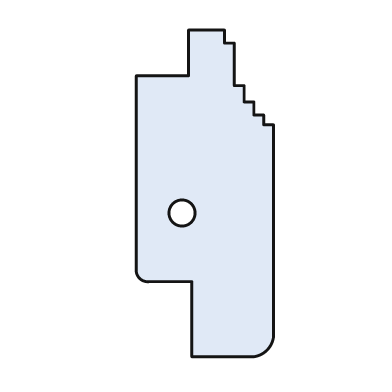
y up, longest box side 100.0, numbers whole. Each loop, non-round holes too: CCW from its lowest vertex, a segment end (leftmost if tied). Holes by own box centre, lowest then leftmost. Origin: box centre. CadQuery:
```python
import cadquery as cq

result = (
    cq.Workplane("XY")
    .moveTo(-4.0, -50.0)
    .lineTo(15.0, -50.0)
    .threePointArc((19.0, -48.0), (21.0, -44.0))
    .lineTo(21.0, 21.0)
    .lineTo(18.0, 21.0)
    .lineTo(18.0, 24.0)
    .lineTo(15.0, 24.0)
    .lineTo(15.0, 28.0)
    .lineTo(12.0, 28.0)
    .lineTo(12.0, 33.0)
    .lineTo(9.0, 33.0)
    .lineTo(9.0, 46.0)
    .lineTo(6.0, 46.0)
    .lineTo(6.0, 50.0)
    .lineTo(-5.0, 50.0)
    .lineTo(-5.0, 36.0)
    .lineTo(-21.0, 36.0)
    .lineTo(-21.0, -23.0)
    .threePointArc((-20.0, -26.0), (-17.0, -27.0))
    .lineTo(-4.0, -27.0)
    .close()
    .moveTo(-7.0, -6.0)
    .circle(4.0)
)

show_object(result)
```